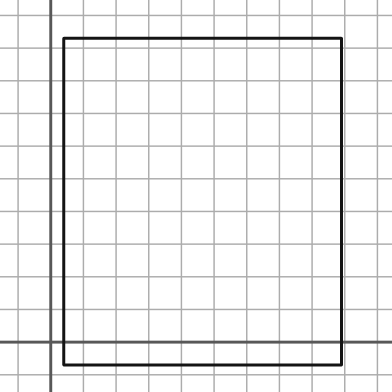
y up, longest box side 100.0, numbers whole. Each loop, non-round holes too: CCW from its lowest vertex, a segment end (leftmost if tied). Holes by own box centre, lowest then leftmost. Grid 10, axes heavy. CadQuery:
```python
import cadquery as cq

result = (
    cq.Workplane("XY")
    .moveTo(4.0, -7.0)
    .lineTo(89.0, -7.0)
    .lineTo(89.0, 93.0)
    .lineTo(4.0, 93.0)
    .close()
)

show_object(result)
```